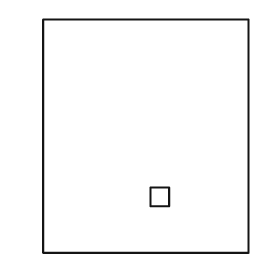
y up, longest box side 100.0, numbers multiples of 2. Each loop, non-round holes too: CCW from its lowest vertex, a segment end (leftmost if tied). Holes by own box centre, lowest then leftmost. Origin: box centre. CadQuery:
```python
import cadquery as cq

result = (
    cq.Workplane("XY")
    .moveTo(-44.0, -50.0)
    .lineTo(44.0, -50.0)
    .lineTo(44.0, 50.0)
    .lineTo(-44.0, 50.0)
    .close()
    .moveTo(2.0, -30.0)
    .lineTo(10.0, -30.0)
    .lineTo(10.0, -22.0)
    .lineTo(2.0, -22.0)
    .close()
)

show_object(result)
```